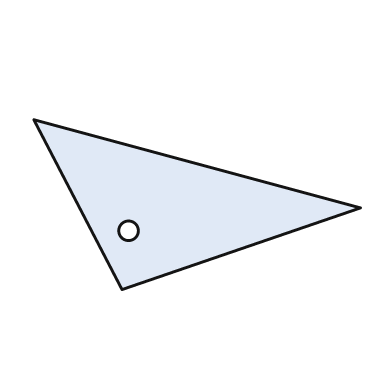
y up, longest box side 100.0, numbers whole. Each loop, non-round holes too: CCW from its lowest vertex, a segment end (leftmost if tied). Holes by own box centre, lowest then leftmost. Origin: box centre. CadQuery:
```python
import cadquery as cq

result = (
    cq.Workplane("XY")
    .moveTo(-23.0, -26.0)
    .lineTo(50.0, -1.0)
    .lineTo(-50.0, 26.0)
    .close()
    .moveTo(-21.0, -8.0)
    .circle(3.0)
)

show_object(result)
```